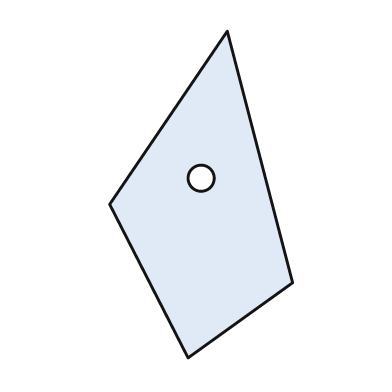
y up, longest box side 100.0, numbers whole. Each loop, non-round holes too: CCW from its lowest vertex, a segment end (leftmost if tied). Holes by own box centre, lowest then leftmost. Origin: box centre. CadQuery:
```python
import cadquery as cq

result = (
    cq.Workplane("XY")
    .moveTo(-4.0, -50.0)
    .lineTo(28.0, -27.0)
    .lineTo(8.0, 50.0)
    .lineTo(-28.0, -3.0)
    .close()
    .moveTo(0.0, 5.0)
    .circle(4.0)
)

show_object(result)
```